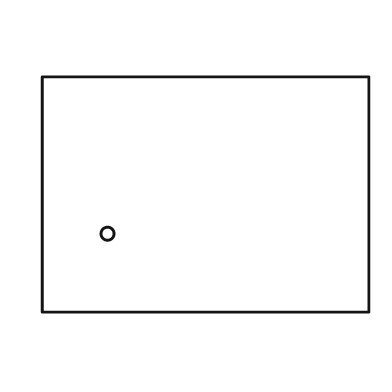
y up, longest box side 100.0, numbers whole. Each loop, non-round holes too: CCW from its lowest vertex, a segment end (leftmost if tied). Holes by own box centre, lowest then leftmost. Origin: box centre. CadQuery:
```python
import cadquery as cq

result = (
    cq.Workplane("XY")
    .moveTo(-50.0, -36.0)
    .lineTo(50.0, -36.0)
    .lineTo(50.0, 36.0)
    .lineTo(-50.0, 36.0)
    .close()
    .moveTo(-30.0, -12.0)
    .circle(2.0)
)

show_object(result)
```